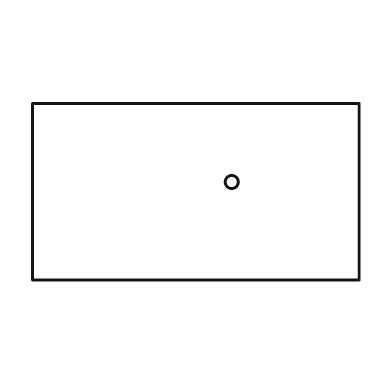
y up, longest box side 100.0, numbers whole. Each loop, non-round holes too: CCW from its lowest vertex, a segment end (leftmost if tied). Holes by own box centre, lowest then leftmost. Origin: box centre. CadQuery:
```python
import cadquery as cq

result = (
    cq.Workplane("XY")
    .moveTo(-50.0, -27.0)
    .lineTo(50.0, -27.0)
    .lineTo(50.0, 27.0)
    .lineTo(-50.0, 27.0)
    .close()
    .moveTo(11.0, 3.0)
    .circle(2.0)
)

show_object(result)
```